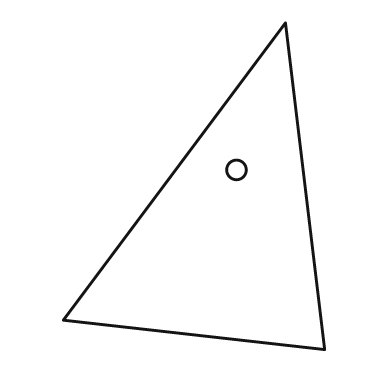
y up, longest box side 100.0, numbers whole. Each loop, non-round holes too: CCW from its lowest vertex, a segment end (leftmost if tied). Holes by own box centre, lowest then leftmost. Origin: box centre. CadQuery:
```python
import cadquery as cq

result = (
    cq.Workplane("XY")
    .moveTo(40.0, -50.0)
    .lineTo(28.0, 50.0)
    .lineTo(-40.0, -41.0)
    .close()
    .moveTo(13.0, 5.0)
    .circle(3.0)
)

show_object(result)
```